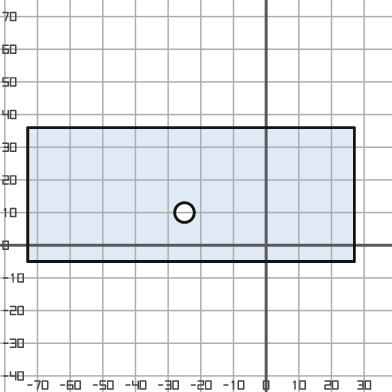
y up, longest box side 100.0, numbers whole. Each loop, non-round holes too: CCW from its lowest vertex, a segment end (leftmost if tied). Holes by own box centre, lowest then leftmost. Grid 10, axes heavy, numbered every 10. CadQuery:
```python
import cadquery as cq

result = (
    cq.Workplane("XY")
    .moveTo(-73.0, -5.0)
    .lineTo(27.0, -5.0)
    .lineTo(27.0, 36.0)
    .lineTo(-73.0, 36.0)
    .close()
    .moveTo(-25.0, 10.0)
    .circle(3.0)
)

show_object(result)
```